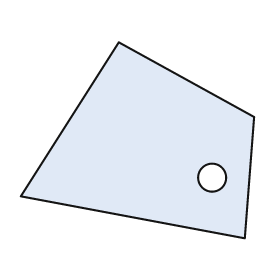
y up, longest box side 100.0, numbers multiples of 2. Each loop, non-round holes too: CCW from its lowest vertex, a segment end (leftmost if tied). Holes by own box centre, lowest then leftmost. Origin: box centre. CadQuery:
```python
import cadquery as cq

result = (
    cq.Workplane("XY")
    .moveTo(46.0, -42.0)
    .lineTo(50.0, 10.0)
    .lineTo(-8.0, 42.0)
    .lineTo(-50.0, -24.0)
    .close()
    .moveTo(32.0, -16.0)
    .circle(6.0)
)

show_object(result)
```